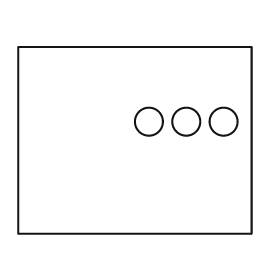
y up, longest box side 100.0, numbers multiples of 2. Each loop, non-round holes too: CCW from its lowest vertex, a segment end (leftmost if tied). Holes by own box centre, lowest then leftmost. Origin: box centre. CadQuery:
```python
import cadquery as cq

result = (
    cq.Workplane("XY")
    .moveTo(-50.0, -40.0)
    .lineTo(50.0, -40.0)
    .lineTo(50.0, 40.0)
    .lineTo(-50.0, 40.0)
    .close()
    .moveTo(6.0, 8.0)
    .circle(6.0)
    .moveTo(22.0, 8.0)
    .circle(6.0)
    .moveTo(38.0, 8.0)
    .circle(6.0)
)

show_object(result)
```